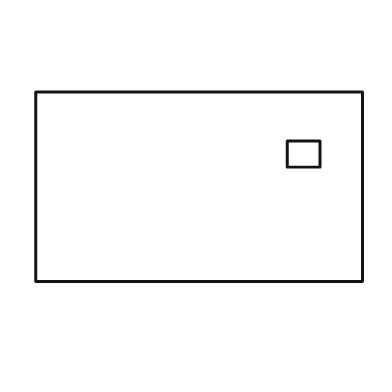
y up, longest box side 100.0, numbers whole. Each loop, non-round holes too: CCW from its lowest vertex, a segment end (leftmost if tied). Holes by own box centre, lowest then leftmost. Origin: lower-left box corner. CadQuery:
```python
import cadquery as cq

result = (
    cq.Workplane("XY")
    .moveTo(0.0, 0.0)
    .lineTo(100.0, 0.0)
    .lineTo(100.0, 58.0)
    .lineTo(0.0, 58.0)
    .close()
    .moveTo(77.0, 35.0)
    .lineTo(87.0, 35.0)
    .lineTo(87.0, 43.0)
    .lineTo(77.0, 43.0)
    .close()
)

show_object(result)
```